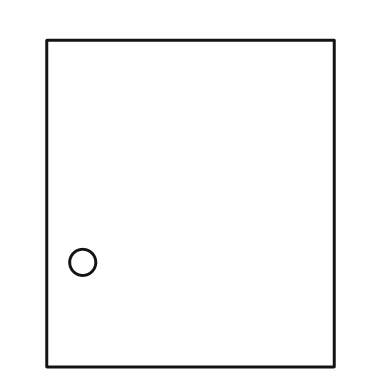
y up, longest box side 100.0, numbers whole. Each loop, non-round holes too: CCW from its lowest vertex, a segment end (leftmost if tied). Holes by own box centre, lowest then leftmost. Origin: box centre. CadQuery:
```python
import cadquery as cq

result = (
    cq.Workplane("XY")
    .moveTo(-44.0, -50.0)
    .lineTo(44.0, -50.0)
    .lineTo(44.0, 50.0)
    .lineTo(-44.0, 50.0)
    .close()
    .moveTo(-33.0, -18.0)
    .circle(4.0)
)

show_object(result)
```